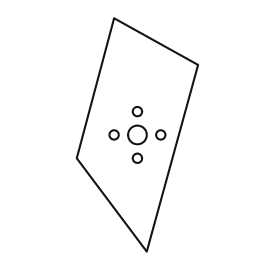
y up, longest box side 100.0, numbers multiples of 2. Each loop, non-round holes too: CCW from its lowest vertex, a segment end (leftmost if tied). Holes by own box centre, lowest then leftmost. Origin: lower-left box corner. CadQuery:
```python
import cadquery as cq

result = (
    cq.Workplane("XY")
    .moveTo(30.0, 0.0)
    .lineTo(52.0, 80.0)
    .lineTo(16.0, 100.0)
    .lineTo(0.0, 40.0)
    .close()
    .moveTo(26.0, 40.0)
    .circle(2.0)
    .moveTo(16.0, 50.0)
    .circle(2.0)
    .moveTo(26.0, 50.0)
    .circle(4.0)
    .moveTo(36.0, 50.0)
    .circle(2.0)
    .moveTo(26.0, 60.0)
    .circle(2.0)
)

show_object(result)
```